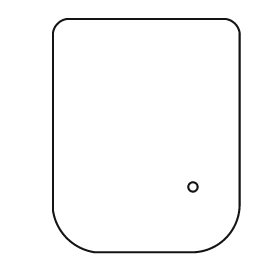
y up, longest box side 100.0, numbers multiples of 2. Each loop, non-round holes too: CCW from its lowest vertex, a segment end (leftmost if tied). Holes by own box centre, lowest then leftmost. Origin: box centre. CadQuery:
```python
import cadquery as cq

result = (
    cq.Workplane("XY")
    .moveTo(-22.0, -50.0)
    .lineTo(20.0, -50.0)
    .threePointArc((34.0, -44.0), (40.0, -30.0))
    .lineTo(40.0, 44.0)
    .threePointArc((38.0, 48.0), (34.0, 50.0))
    .lineTo(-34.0, 50.0)
    .threePointArc((-38.0, 48.0), (-40.0, 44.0))
    .lineTo(-40.0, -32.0)
    .threePointArc((-34.0, -44.0), (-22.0, -50.0))
    .close()
    .moveTo(20.0, -22.0)
    .circle(2.0)
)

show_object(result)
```